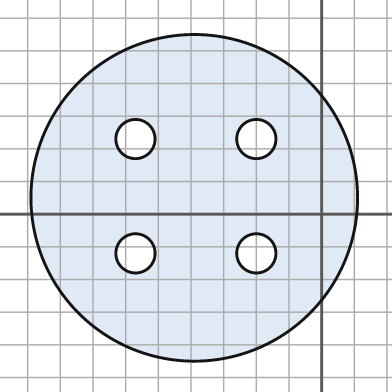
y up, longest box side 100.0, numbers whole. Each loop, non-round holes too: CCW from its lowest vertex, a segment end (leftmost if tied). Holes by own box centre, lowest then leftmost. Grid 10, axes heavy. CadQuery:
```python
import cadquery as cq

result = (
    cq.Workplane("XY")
    .moveTo(-39.0, 5.0)
    .circle(50.0)
    .moveTo(-57.0, -12.0)
    .circle(6.0)
    .moveTo(-20.0, -12.0)
    .circle(6.0)
    .moveTo(-57.0, 23.0)
    .circle(6.0)
    .moveTo(-20.0, 23.0)
    .circle(6.0)
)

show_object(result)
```